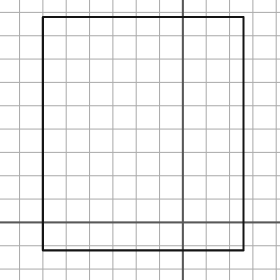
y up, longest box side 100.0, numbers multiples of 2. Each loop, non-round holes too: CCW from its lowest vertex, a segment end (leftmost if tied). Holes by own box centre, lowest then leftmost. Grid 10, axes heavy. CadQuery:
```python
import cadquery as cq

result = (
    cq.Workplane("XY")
    .moveTo(-60.0, -12.0)
    .lineTo(26.0, -12.0)
    .lineTo(26.0, 88.0)
    .lineTo(-60.0, 88.0)
    .close()
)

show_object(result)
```